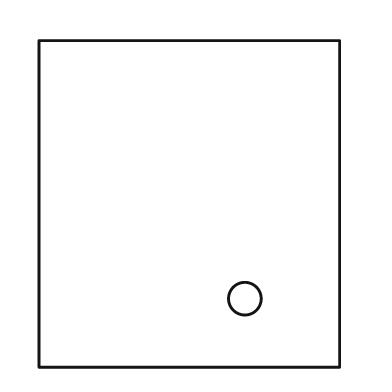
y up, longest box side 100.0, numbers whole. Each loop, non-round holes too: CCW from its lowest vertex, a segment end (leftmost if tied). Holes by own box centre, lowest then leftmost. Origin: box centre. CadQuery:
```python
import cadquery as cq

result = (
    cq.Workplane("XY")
    .moveTo(-46.0, -50.0)
    .lineTo(46.0, -50.0)
    .lineTo(46.0, 50.0)
    .lineTo(-46.0, 50.0)
    .close()
    .moveTo(17.0, -29.0)
    .circle(5.0)
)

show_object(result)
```